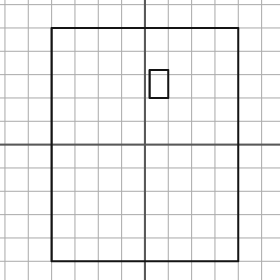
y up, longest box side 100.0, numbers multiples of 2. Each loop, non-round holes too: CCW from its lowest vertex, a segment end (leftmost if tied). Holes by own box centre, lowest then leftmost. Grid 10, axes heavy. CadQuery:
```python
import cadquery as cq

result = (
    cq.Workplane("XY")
    .moveTo(-40.0, -50.0)
    .lineTo(40.0, -50.0)
    .lineTo(40.0, 50.0)
    .lineTo(-40.0, 50.0)
    .close()
    .moveTo(2.0, 20.0)
    .lineTo(10.0, 20.0)
    .lineTo(10.0, 32.0)
    .lineTo(2.0, 32.0)
    .close()
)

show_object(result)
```